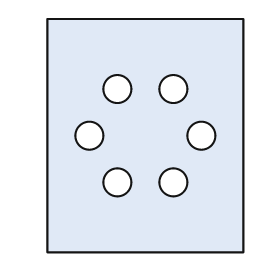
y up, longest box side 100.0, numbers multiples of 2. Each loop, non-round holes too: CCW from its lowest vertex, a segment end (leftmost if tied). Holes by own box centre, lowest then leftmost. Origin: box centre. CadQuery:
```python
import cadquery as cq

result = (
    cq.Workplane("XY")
    .moveTo(-42.0, -50.0)
    .lineTo(42.0, -50.0)
    .lineTo(42.0, 50.0)
    .lineTo(-42.0, 50.0)
    .close()
    .moveTo(-12.0, -20.0)
    .circle(6.0)
    .moveTo(12.0, -20.0)
    .circle(6.0)
    .moveTo(-24.0, 0.0)
    .circle(6.0)
    .moveTo(24.0, 0.0)
    .circle(6.0)
    .moveTo(-12.0, 20.0)
    .circle(6.0)
    .moveTo(12.0, 20.0)
    .circle(6.0)
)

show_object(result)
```